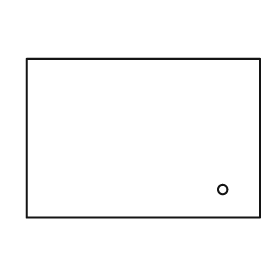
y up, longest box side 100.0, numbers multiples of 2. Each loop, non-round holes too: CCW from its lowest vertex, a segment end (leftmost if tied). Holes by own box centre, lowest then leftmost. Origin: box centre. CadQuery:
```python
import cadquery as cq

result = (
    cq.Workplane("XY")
    .moveTo(-50.0, -34.0)
    .lineTo(50.0, -34.0)
    .lineTo(50.0, 34.0)
    .lineTo(-50.0, 34.0)
    .close()
    .moveTo(34.0, -22.0)
    .circle(2.0)
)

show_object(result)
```